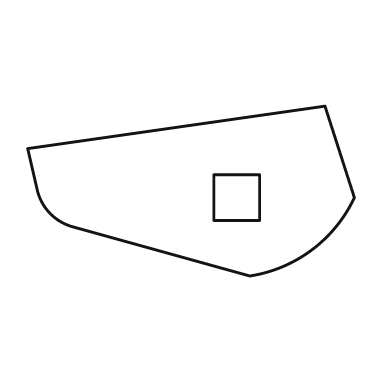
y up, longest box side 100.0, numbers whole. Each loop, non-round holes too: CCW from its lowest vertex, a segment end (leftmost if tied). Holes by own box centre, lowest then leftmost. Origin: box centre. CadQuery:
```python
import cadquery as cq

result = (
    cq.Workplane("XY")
    .moveTo(18.0, -26.0)
    .threePointArc((37.0, -18.0), (50.0, -2.0))
    .lineTo(41.0, 26.0)
    .lineTo(-50.0, 13.0)
    .lineTo(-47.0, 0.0)
    .threePointArc((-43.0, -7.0), (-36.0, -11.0))
    .close()
    .moveTo(7.0, -9.0)
    .lineTo(21.0, -9.0)
    .lineTo(21.0, 5.0)
    .lineTo(7.0, 5.0)
    .close()
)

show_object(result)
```